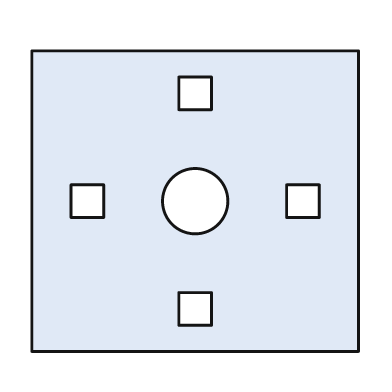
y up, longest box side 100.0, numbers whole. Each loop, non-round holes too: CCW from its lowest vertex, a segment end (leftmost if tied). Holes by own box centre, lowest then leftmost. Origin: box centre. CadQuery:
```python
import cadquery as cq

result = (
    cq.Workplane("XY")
    .moveTo(-50.0, -46.0)
    .lineTo(50.0, -46.0)
    .lineTo(50.0, 46.0)
    .lineTo(-50.0, 46.0)
    .close()
    .moveTo(-5.0, -38.0)
    .lineTo(5.0, -38.0)
    .lineTo(5.0, -28.0)
    .lineTo(-5.0, -28.0)
    .close()
    .moveTo(-38.0, -5.0)
    .lineTo(-28.0, -5.0)
    .lineTo(-28.0, 5.0)
    .lineTo(-38.0, 5.0)
    .close()
    .moveTo(0.0, 0.0)
    .circle(10.0)
    .moveTo(28.0, -5.0)
    .lineTo(38.0, -5.0)
    .lineTo(38.0, 5.0)
    .lineTo(28.0, 5.0)
    .close()
    .moveTo(-5.0, 28.0)
    .lineTo(5.0, 28.0)
    .lineTo(5.0, 38.0)
    .lineTo(-5.0, 38.0)
    .close()
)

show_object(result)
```